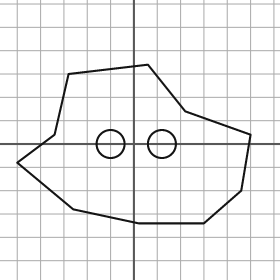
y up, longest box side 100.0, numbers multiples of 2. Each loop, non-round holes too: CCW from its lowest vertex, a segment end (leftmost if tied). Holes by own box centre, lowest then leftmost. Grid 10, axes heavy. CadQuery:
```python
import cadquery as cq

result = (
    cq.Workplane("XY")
    .moveTo(2.0, -34.0)
    .lineTo(30.0, -34.0)
    .lineTo(46.0, -20.0)
    .lineTo(50.0, 4.0)
    .lineTo(22.0, 14.0)
    .lineTo(6.0, 34.0)
    .lineTo(-28.0, 30.0)
    .lineTo(-34.0, 4.0)
    .lineTo(-50.0, -8.0)
    .lineTo(-26.0, -28.0)
    .close()
    .moveTo(-10.0, 0.0)
    .circle(6.0)
    .moveTo(12.0, 0.0)
    .circle(6.0)
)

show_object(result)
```